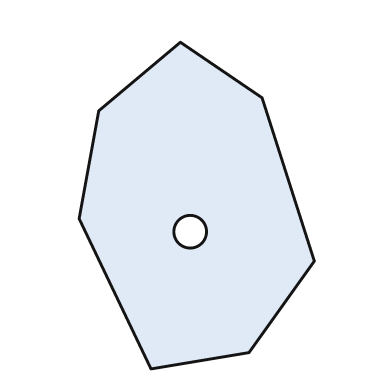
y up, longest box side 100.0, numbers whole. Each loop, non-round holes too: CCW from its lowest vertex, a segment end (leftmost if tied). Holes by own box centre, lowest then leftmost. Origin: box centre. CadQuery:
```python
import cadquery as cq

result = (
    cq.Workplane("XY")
    .moveTo(-14.0, -50.0)
    .lineTo(16.0, -45.0)
    .lineTo(36.0, -17.0)
    .lineTo(20.0, 33.0)
    .lineTo(-5.0, 50.0)
    .lineTo(-30.0, 29.0)
    .lineTo(-36.0, -4.0)
    .close()
    .moveTo(-2.0, -8.0)
    .circle(5.0)
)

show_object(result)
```